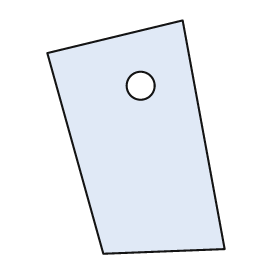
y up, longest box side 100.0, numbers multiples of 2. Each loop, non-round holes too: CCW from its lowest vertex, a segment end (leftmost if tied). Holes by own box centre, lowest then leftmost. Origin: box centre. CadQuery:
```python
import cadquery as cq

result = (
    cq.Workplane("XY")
    .moveTo(-14.0, -50.0)
    .lineTo(38.0, -48.0)
    .lineTo(20.0, 50.0)
    .lineTo(-38.0, 36.0)
    .close()
    .moveTo(2.0, 22.0)
    .circle(6.0)
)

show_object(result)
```